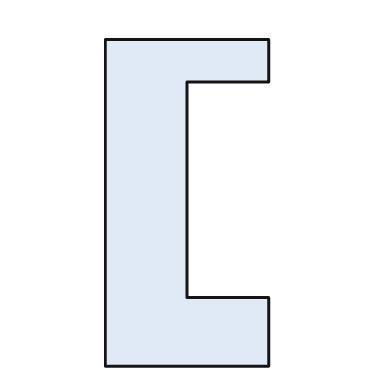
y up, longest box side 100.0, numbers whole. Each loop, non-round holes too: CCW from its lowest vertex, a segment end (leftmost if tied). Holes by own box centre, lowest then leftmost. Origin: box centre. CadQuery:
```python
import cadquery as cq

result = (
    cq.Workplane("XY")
    .moveTo(-25.0, -50.0)
    .lineTo(25.0, -50.0)
    .lineTo(25.0, -29.0)
    .lineTo(0.0, -29.0)
    .lineTo(0.0, 37.0)
    .lineTo(25.0, 37.0)
    .lineTo(25.0, 50.0)
    .lineTo(-25.0, 50.0)
    .close()
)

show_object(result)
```